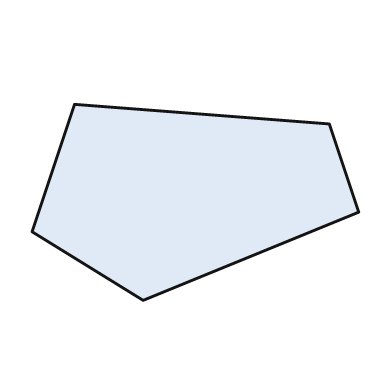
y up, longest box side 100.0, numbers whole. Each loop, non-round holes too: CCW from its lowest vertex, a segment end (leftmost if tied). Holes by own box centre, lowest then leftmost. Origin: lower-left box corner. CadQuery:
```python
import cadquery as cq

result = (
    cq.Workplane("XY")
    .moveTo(34.0, 0.0)
    .lineTo(100.0, 27.0)
    .lineTo(91.0, 54.0)
    .lineTo(13.0, 60.0)
    .lineTo(0.0, 21.0)
    .close()
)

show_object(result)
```